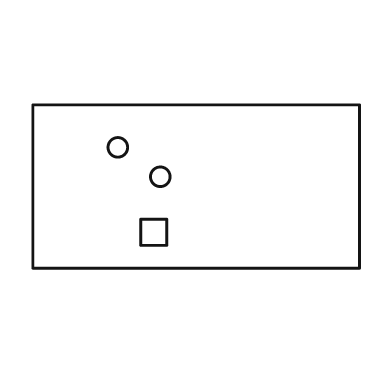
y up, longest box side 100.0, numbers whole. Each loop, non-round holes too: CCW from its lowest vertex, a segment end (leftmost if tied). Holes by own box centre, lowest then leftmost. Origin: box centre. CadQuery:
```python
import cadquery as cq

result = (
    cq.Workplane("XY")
    .moveTo(-50.0, -25.0)
    .lineTo(50.0, -25.0)
    .lineTo(50.0, 25.0)
    .lineTo(-50.0, 25.0)
    .close()
    .moveTo(-17.0, -18.0)
    .lineTo(-9.0, -18.0)
    .lineTo(-9.0, -10.0)
    .lineTo(-17.0, -10.0)
    .close()
    .moveTo(-11.0, 3.0)
    .circle(3.0)
    .moveTo(-24.0, 12.0)
    .circle(3.0)
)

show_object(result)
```